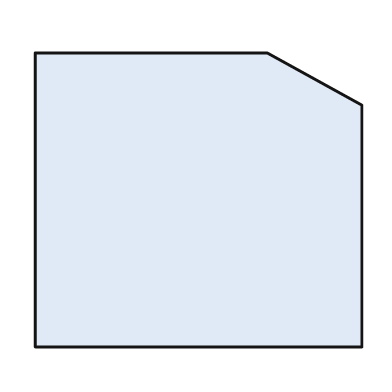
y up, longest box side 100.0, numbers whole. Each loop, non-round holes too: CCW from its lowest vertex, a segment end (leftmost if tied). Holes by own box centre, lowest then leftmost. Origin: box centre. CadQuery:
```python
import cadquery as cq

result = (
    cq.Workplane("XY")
    .moveTo(-50.0, -45.0)
    .lineTo(50.0, -45.0)
    .lineTo(50.0, 29.0)
    .lineTo(21.0, 45.0)
    .lineTo(-50.0, 45.0)
    .close()
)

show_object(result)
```